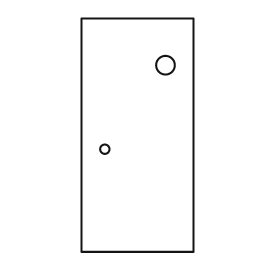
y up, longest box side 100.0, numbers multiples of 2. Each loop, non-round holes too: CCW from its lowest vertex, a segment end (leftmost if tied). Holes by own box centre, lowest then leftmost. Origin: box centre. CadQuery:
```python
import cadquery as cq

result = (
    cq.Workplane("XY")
    .moveTo(-24.0, -50.0)
    .lineTo(24.0, -50.0)
    .lineTo(24.0, 50.0)
    .lineTo(-24.0, 50.0)
    .close()
    .moveTo(-14.0, -6.0)
    .circle(2.0)
    .moveTo(12.0, 30.0)
    .circle(4.0)
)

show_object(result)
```